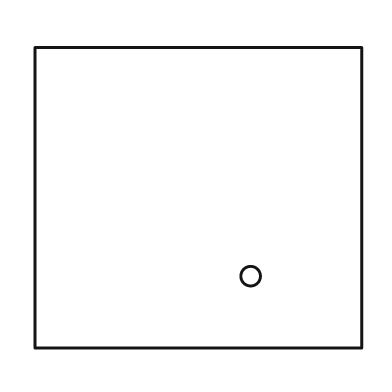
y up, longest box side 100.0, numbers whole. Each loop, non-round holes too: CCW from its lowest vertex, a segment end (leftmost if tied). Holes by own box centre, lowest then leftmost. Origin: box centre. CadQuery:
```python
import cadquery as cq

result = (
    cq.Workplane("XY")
    .moveTo(-50.0, -46.0)
    .lineTo(50.0, -46.0)
    .lineTo(50.0, 46.0)
    .lineTo(-50.0, 46.0)
    .close()
    .moveTo(16.0, -24.0)
    .circle(3.0)
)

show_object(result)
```